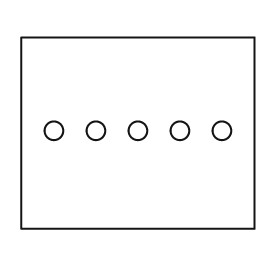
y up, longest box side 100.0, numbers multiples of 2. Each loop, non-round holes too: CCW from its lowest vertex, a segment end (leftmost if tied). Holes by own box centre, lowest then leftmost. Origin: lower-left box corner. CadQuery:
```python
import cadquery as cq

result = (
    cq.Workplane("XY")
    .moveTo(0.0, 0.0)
    .lineTo(100.0, 0.0)
    .lineTo(100.0, 82.0)
    .lineTo(0.0, 82.0)
    .close()
    .moveTo(14.0, 42.0)
    .circle(4.0)
    .moveTo(32.0, 42.0)
    .circle(4.0)
    .moveTo(50.0, 42.0)
    .circle(4.0)
    .moveTo(68.0, 42.0)
    .circle(4.0)
    .moveTo(86.0, 42.0)
    .circle(4.0)
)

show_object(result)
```